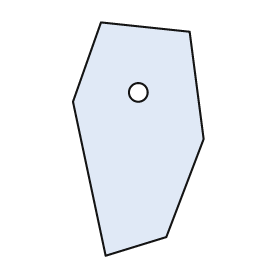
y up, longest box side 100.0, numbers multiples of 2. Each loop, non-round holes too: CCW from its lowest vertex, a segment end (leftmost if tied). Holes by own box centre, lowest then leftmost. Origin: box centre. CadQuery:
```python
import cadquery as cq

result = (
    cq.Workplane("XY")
    .moveTo(-14.0, -50.0)
    .lineTo(12.0, -42.0)
    .lineTo(28.0, 0.0)
    .lineTo(22.0, 46.0)
    .lineTo(-16.0, 50.0)
    .lineTo(-28.0, 16.0)
    .close()
    .moveTo(0.0, 20.0)
    .circle(4.0)
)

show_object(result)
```